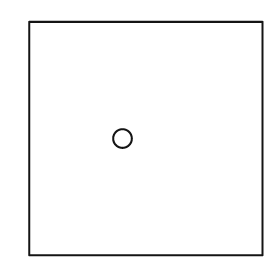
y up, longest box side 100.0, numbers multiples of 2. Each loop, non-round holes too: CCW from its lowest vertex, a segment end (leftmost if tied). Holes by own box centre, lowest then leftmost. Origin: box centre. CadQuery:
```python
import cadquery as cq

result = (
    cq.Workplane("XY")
    .moveTo(-50.0, -50.0)
    .lineTo(50.0, -50.0)
    .lineTo(50.0, 50.0)
    .lineTo(-50.0, 50.0)
    .close()
    .moveTo(-10.0, 0.0)
    .circle(4.0)
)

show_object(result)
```